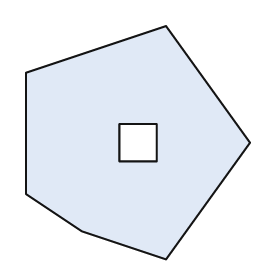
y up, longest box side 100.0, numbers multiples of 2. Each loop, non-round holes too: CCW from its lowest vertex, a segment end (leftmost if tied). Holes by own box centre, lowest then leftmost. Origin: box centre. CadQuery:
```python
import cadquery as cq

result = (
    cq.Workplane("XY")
    .moveTo(12.0, -50.0)
    .lineTo(48.0, 0.0)
    .lineTo(12.0, 50.0)
    .lineTo(-48.0, 30.0)
    .lineTo(-48.0, -22.0)
    .lineTo(-24.0, -38.0)
    .close()
    .moveTo(-8.0, -8.0)
    .lineTo(8.0, -8.0)
    .lineTo(8.0, 8.0)
    .lineTo(-8.0, 8.0)
    .close()
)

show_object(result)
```